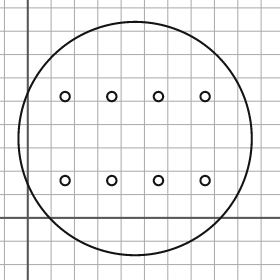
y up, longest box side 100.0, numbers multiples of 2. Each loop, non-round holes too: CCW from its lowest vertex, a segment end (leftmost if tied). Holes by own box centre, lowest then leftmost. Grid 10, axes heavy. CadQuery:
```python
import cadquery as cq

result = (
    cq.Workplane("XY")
    .moveTo(46.0, 34.0)
    .circle(50.0)
    .moveTo(16.0, 16.0)
    .circle(2.0)
    .moveTo(36.0, 16.0)
    .circle(2.0)
    .moveTo(56.0, 16.0)
    .circle(2.0)
    .moveTo(76.0, 16.0)
    .circle(2.0)
    .moveTo(16.0, 52.0)
    .circle(2.0)
    .moveTo(36.0, 52.0)
    .circle(2.0)
    .moveTo(56.0, 52.0)
    .circle(2.0)
    .moveTo(76.0, 52.0)
    .circle(2.0)
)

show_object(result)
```